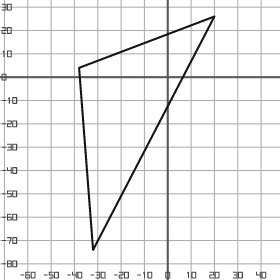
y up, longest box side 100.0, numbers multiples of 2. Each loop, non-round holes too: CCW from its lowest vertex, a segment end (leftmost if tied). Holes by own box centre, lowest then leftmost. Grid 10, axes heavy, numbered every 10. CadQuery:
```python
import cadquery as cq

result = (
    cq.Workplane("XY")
    .moveTo(-32.0, -74.0)
    .lineTo(20.0, 26.0)
    .lineTo(-38.0, 4.0)
    .close()
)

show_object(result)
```